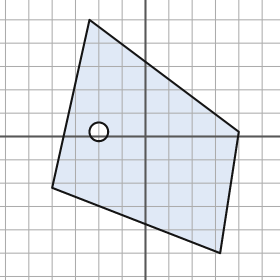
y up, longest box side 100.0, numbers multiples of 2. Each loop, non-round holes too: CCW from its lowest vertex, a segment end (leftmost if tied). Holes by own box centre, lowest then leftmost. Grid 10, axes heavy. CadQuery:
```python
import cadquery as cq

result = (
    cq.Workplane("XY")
    .moveTo(32.0, -50.0)
    .lineTo(40.0, 2.0)
    .lineTo(-24.0, 50.0)
    .lineTo(-40.0, -22.0)
    .close()
    .moveTo(-20.0, 2.0)
    .circle(4.0)
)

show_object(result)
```